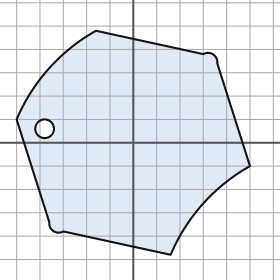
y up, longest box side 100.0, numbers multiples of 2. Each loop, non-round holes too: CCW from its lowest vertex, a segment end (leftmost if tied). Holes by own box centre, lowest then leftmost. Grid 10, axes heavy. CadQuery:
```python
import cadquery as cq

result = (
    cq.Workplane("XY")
    .moveTo(16.0, -48.0)
    .threePointArc((30.0, -26.0), (50.0, -10.0))
    .lineTo(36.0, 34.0)
    .threePointArc((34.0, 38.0), (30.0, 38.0))
    .lineTo(-16.0, 48.0)
    .threePointArc((-36.0, 32.0), (-50.0, 10.0))
    .lineTo(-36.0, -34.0)
    .threePointArc((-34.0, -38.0), (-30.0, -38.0))
    .close()
    .moveTo(-38.0, 6.0)
    .circle(4.0)
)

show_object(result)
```